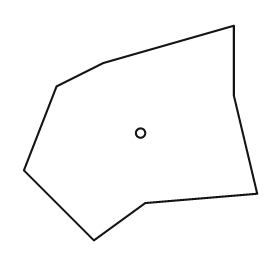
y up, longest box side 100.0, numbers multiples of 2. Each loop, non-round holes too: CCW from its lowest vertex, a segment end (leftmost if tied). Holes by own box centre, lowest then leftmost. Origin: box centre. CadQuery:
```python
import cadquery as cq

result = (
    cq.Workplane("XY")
    .moveTo(-20.0, -46.0)
    .lineTo(2.0, -30.0)
    .lineTo(50.0, -26.0)
    .lineTo(40.0, 16.0)
    .lineTo(40.0, 46.0)
    .lineTo(-16.0, 30.0)
    .lineTo(-36.0, 20.0)
    .lineTo(-50.0, -16.0)
    .close()
    .moveTo(0.0, 0.0)
    .circle(2.0)
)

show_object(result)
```